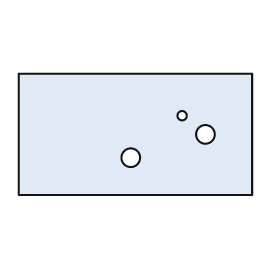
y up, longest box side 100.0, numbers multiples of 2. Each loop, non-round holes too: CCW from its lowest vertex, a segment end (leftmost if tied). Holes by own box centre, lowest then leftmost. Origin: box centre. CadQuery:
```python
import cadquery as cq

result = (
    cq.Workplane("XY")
    .moveTo(-50.0, -26.0)
    .lineTo(50.0, -26.0)
    .lineTo(50.0, 26.0)
    .lineTo(-50.0, 26.0)
    .close()
    .moveTo(-2.0, -10.0)
    .circle(4.0)
    .moveTo(30.0, 0.0)
    .circle(4.0)
    .moveTo(20.0, 8.0)
    .circle(2.0)
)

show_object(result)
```